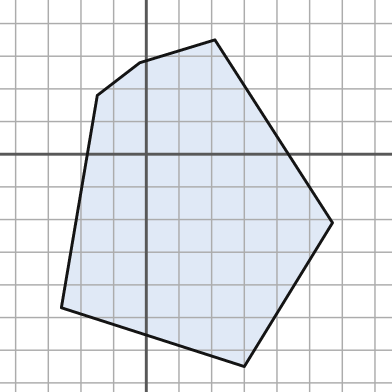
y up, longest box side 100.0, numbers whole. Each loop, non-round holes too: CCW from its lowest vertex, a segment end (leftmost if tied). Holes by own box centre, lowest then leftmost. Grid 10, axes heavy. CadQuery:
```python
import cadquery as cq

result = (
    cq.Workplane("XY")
    .moveTo(30.0, -65.0)
    .lineTo(57.0, -21.0)
    .lineTo(21.0, 35.0)
    .lineTo(-2.0, 28.0)
    .lineTo(-15.0, 18.0)
    .lineTo(-26.0, -47.0)
    .close()
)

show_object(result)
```